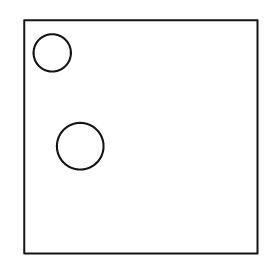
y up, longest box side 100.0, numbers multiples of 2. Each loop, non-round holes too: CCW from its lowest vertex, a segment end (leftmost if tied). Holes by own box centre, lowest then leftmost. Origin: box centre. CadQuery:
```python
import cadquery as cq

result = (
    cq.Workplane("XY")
    .moveTo(-50.0, -50.0)
    .lineTo(50.0, -50.0)
    .lineTo(50.0, 50.0)
    .lineTo(-50.0, 50.0)
    .close()
    .moveTo(-26.0, -4.0)
    .circle(10.0)
    .moveTo(-38.0, 36.0)
    .circle(8.0)
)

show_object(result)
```